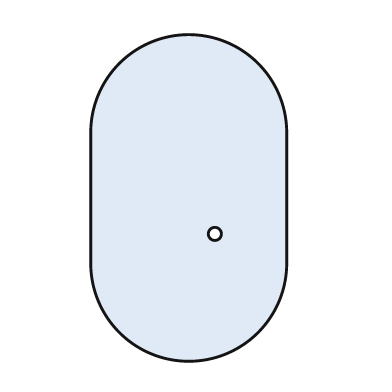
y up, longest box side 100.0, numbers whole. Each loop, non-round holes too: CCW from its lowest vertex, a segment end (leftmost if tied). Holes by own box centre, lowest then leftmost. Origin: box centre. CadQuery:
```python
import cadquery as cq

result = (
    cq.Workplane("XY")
    .moveTo(-30.0, -20.0)
    .threePointArc((0.0, -50.0), (30.0, -20.0))
    .lineTo(30.0, 20.0)
    .threePointArc((0.0, 50.0), (-30.0, 20.0))
    .close()
    .moveTo(8.0, -11.0)
    .circle(2.0)
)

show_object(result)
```